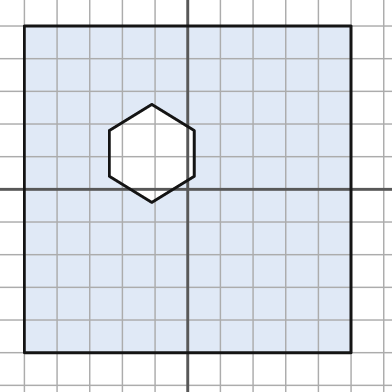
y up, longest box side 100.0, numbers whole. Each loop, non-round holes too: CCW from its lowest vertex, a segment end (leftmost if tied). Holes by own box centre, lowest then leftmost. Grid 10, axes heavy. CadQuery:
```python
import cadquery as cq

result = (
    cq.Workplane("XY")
    .moveTo(-50.0, -50.0)
    .lineTo(50.0, -50.0)
    .lineTo(50.0, 50.0)
    .lineTo(-50.0, 50.0)
    .close()
    .moveTo(-11.0, -4.0)
    .lineTo(2.0, 4.0)
    .lineTo(2.0, 18.0)
    .lineTo(-11.0, 26.0)
    .lineTo(-24.0, 18.0)
    .lineTo(-24.0, 4.0)
    .close()
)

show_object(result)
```